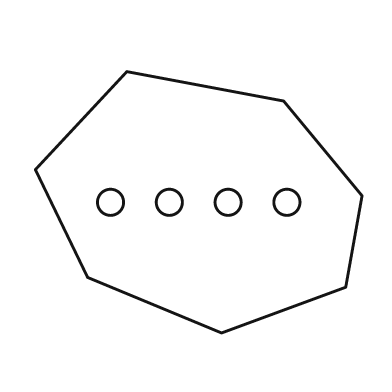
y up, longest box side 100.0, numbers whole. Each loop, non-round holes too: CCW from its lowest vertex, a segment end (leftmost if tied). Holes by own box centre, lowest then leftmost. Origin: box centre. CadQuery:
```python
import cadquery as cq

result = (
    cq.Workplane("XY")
    .moveTo(7.0, -40.0)
    .lineTo(45.0, -26.0)
    .lineTo(50.0, 2.0)
    .lineTo(26.0, 31.0)
    .lineTo(-22.0, 40.0)
    .lineTo(-50.0, 10.0)
    .lineTo(-34.0, -23.0)
    .close()
    .moveTo(-27.0, 0.0)
    .circle(4.0)
    .moveTo(-9.0, 0.0)
    .circle(4.0)
    .moveTo(9.0, 0.0)
    .circle(4.0)
    .moveTo(27.0, 0.0)
    .circle(4.0)
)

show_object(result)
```